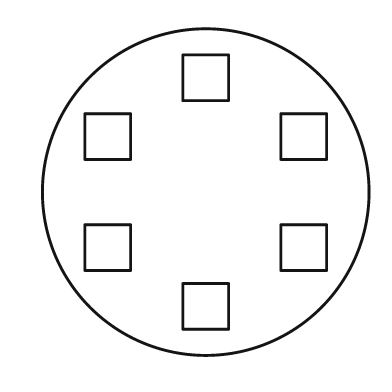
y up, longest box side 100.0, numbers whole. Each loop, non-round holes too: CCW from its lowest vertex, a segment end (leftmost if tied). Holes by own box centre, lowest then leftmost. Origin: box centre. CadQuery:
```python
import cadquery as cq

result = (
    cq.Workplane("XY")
    .moveTo(0.0, 0.0)
    .circle(50.0)
    .moveTo(-7.0, -42.0)
    .lineTo(7.0, -42.0)
    .lineTo(7.0, -28.0)
    .lineTo(-7.0, -28.0)
    .close()
    .moveTo(-37.0, -24.0)
    .lineTo(-23.0, -24.0)
    .lineTo(-23.0, -10.0)
    .lineTo(-37.0, -10.0)
    .close()
    .moveTo(23.0, -24.0)
    .lineTo(37.0, -24.0)
    .lineTo(37.0, -10.0)
    .lineTo(23.0, -10.0)
    .close()
    .moveTo(-37.0, 10.0)
    .lineTo(-23.0, 10.0)
    .lineTo(-23.0, 24.0)
    .lineTo(-37.0, 24.0)
    .close()
    .moveTo(23.0, 10.0)
    .lineTo(37.0, 10.0)
    .lineTo(37.0, 24.0)
    .lineTo(23.0, 24.0)
    .close()
    .moveTo(-7.0, 28.0)
    .lineTo(7.0, 28.0)
    .lineTo(7.0, 42.0)
    .lineTo(-7.0, 42.0)
    .close()
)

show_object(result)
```